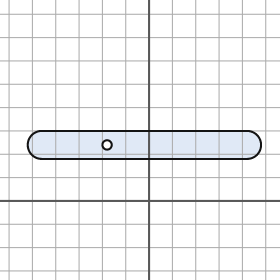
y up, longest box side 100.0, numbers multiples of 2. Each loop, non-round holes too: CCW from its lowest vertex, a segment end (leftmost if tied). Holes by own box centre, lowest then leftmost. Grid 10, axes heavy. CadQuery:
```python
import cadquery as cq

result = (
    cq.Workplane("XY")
    .moveTo(-46.0, 18.0)
    .lineTo(42.0, 18.0)
    .threePointArc((48.0, 24.0), (42.0, 30.0))
    .lineTo(-46.0, 30.0)
    .threePointArc((-52.0, 24.0), (-46.0, 18.0))
    .close()
    .moveTo(-18.0, 24.0)
    .circle(2.0)
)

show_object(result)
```